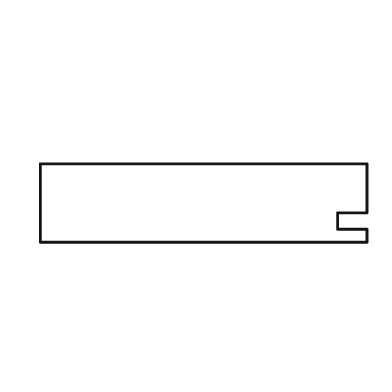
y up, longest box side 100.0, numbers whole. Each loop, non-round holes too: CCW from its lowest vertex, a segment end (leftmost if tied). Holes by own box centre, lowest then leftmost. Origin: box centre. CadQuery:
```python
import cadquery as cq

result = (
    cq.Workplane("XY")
    .moveTo(-50.0, -12.0)
    .lineTo(50.0, -12.0)
    .lineTo(50.0, -8.0)
    .lineTo(41.0, -8.0)
    .lineTo(41.0, -3.0)
    .lineTo(50.0, -3.0)
    .lineTo(50.0, 12.0)
    .lineTo(-50.0, 12.0)
    .close()
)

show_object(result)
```